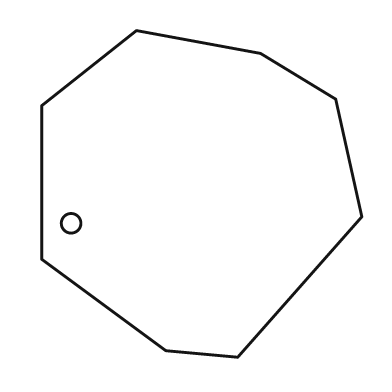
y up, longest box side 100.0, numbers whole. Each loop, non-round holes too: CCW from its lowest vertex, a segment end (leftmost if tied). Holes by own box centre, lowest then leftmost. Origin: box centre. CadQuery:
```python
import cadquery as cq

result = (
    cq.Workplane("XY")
    .moveTo(11.0, -50.0)
    .lineTo(49.0, -7.0)
    .lineTo(41.0, 29.0)
    .lineTo(18.0, 43.0)
    .lineTo(-20.0, 50.0)
    .lineTo(-49.0, 27.0)
    .lineTo(-49.0, -20.0)
    .lineTo(-11.0, -48.0)
    .close()
    .moveTo(-40.0, -9.0)
    .circle(3.0)
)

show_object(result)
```